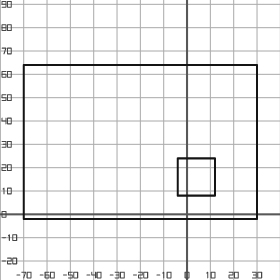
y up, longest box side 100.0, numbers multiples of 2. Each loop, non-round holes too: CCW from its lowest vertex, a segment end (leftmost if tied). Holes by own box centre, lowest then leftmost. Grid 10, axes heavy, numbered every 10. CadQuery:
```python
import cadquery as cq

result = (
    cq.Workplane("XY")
    .moveTo(-70.0, -2.0)
    .lineTo(30.0, -2.0)
    .lineTo(30.0, 64.0)
    .lineTo(-70.0, 64.0)
    .close()
    .moveTo(-4.0, 8.0)
    .lineTo(12.0, 8.0)
    .lineTo(12.0, 24.0)
    .lineTo(-4.0, 24.0)
    .close()
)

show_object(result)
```